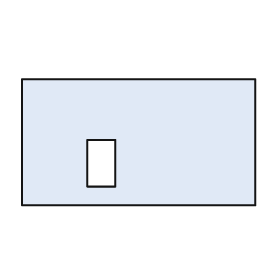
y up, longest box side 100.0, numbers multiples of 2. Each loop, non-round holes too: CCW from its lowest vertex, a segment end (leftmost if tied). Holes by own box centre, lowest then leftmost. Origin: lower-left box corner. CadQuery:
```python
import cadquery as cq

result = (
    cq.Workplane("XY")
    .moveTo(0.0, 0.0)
    .lineTo(100.0, 0.0)
    .lineTo(100.0, 54.0)
    .lineTo(0.0, 54.0)
    .close()
    .moveTo(28.0, 8.0)
    .lineTo(40.0, 8.0)
    .lineTo(40.0, 28.0)
    .lineTo(28.0, 28.0)
    .close()
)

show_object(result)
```